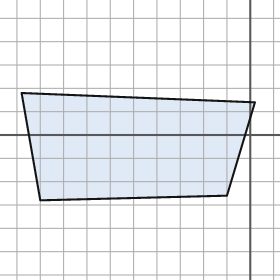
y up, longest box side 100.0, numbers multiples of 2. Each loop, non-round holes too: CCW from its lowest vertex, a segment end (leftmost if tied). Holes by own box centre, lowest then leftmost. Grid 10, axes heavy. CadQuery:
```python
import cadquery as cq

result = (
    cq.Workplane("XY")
    .moveTo(-90.0, -28.0)
    .lineTo(-10.0, -26.0)
    .lineTo(2.0, 14.0)
    .lineTo(-98.0, 18.0)
    .close()
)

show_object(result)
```